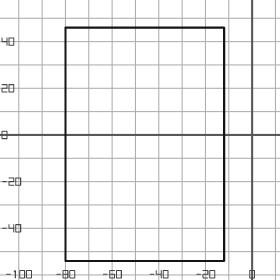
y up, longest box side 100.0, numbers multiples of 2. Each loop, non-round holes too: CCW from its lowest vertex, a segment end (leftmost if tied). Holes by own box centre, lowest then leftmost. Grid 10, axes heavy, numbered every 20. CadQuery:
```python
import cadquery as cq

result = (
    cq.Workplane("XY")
    .moveTo(-80.0, -54.0)
    .lineTo(-12.0, -54.0)
    .lineTo(-12.0, 46.0)
    .lineTo(-80.0, 46.0)
    .close()
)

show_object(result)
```